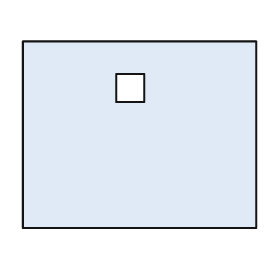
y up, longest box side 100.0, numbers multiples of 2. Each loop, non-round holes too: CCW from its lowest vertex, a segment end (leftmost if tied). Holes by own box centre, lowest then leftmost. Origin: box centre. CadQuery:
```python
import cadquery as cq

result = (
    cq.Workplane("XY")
    .moveTo(-50.0, -40.0)
    .lineTo(50.0, -40.0)
    .lineTo(50.0, 40.0)
    .lineTo(-50.0, 40.0)
    .close()
    .moveTo(-10.0, 14.0)
    .lineTo(2.0, 14.0)
    .lineTo(2.0, 26.0)
    .lineTo(-10.0, 26.0)
    .close()
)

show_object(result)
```